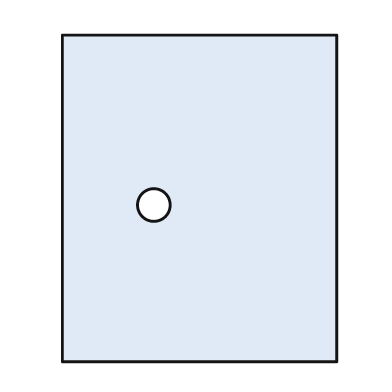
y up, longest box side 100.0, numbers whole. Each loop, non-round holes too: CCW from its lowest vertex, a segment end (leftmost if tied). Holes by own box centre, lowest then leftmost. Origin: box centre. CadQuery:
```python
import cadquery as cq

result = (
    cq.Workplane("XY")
    .moveTo(-42.0, -50.0)
    .lineTo(42.0, -50.0)
    .lineTo(42.0, 50.0)
    .lineTo(-42.0, 50.0)
    .close()
    .moveTo(-14.0, -2.0)
    .circle(5.0)
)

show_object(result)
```